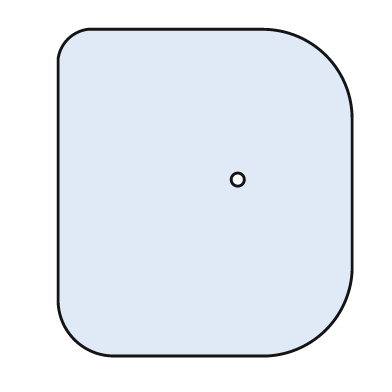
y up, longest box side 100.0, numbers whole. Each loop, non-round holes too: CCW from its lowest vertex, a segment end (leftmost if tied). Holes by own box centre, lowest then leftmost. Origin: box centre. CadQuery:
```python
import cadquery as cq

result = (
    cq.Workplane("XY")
    .moveTo(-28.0, -50.0)
    .lineTo(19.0, -50.0)
    .threePointArc((37.0, -42.0), (45.0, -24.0))
    .lineTo(45.0, 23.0)
    .threePointArc((37.0, 42.0), (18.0, 50.0))
    .lineTo(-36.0, 50.0)
    .threePointArc((-42.0, 47.0), (-45.0, 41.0))
    .lineTo(-45.0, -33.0)
    .threePointArc((-40.0, -45.0), (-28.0, -50.0))
    .close()
    .moveTo(10.0, 4.0)
    .circle(2.0)
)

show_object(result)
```